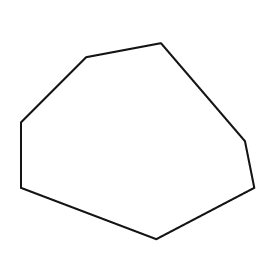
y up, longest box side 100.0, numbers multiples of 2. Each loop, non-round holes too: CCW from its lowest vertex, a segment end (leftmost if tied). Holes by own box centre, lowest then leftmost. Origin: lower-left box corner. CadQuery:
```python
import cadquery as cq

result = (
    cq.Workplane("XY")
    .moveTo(58.0, 0.0)
    .lineTo(100.0, 22.0)
    .lineTo(96.0, 42.0)
    .lineTo(60.0, 84.0)
    .lineTo(28.0, 78.0)
    .lineTo(0.0, 50.0)
    .lineTo(0.0, 22.0)
    .close()
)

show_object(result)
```